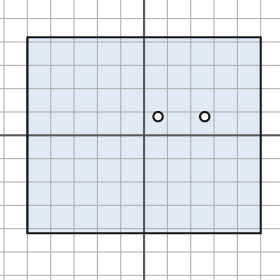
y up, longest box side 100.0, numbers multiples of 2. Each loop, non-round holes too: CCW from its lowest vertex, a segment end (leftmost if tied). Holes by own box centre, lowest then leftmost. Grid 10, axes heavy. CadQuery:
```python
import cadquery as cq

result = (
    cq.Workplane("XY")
    .moveTo(-50.0, -42.0)
    .lineTo(50.0, -42.0)
    .lineTo(50.0, 42.0)
    .lineTo(-50.0, 42.0)
    .close()
    .moveTo(6.0, 8.0)
    .circle(2.0)
    .moveTo(26.0, 8.0)
    .circle(2.0)
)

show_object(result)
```